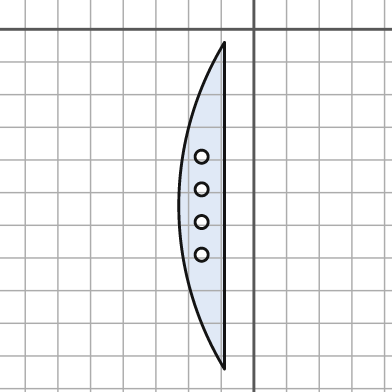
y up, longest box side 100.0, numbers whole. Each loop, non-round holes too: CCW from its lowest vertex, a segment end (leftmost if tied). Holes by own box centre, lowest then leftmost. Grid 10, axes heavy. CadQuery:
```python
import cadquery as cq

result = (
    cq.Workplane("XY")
    .moveTo(-9.0, -104.0)
    .lineTo(-9.0, -4.0)
    .threePointArc((-23.0, -54.0), (-9.0, -104.0))
    .close()
    .moveTo(-16.0, -69.0)
    .circle(2.0)
    .moveTo(-16.0, -59.0)
    .circle(2.0)
    .moveTo(-16.0, -49.0)
    .circle(2.0)
    .moveTo(-16.0, -39.0)
    .circle(2.0)
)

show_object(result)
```